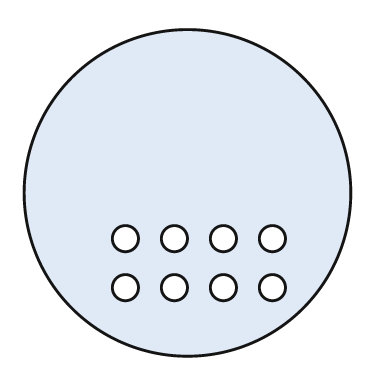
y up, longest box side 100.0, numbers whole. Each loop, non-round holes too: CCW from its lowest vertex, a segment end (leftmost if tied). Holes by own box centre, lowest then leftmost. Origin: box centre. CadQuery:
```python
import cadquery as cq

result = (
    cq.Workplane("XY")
    .moveTo(0.0, 0.0)
    .circle(50.0)
    .moveTo(-19.0, -29.0)
    .circle(4.0)
    .moveTo(-4.0, -29.0)
    .circle(4.0)
    .moveTo(11.0, -29.0)
    .circle(4.0)
    .moveTo(26.0, -29.0)
    .circle(4.0)
    .moveTo(-19.0, -14.0)
    .circle(4.0)
    .moveTo(-4.0, -14.0)
    .circle(4.0)
    .moveTo(11.0, -14.0)
    .circle(4.0)
    .moveTo(26.0, -14.0)
    .circle(4.0)
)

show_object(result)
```